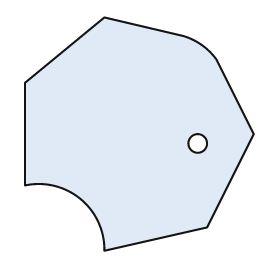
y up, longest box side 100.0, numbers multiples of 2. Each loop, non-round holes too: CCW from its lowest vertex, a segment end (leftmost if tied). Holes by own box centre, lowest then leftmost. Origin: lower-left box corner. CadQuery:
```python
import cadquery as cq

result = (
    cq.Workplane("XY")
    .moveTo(34.0, 0.0)
    .lineTo(78.0, 10.0)
    .lineTo(98.0, 50.0)
    .lineTo(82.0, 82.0)
    .threePointArc((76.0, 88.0), (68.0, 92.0))
    .lineTo(34.0, 100.0)
    .lineTo(0.0, 72.0)
    .lineTo(0.0, 28.0)
    .threePointArc((24.0, 22.0), (34.0, 0.0))
    .close()
    .moveTo(74.0, 46.0)
    .circle(4.0)
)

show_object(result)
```